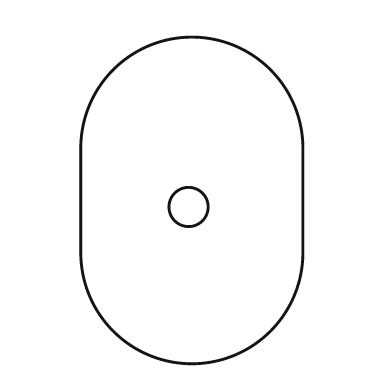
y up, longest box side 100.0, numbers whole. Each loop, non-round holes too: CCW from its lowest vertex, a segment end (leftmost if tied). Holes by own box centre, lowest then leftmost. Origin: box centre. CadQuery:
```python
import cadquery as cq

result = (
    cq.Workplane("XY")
    .moveTo(-34.0, -16.0)
    .threePointArc((0.0, -50.0), (34.0, -16.0))
    .lineTo(34.0, 16.0)
    .threePointArc((0.0, 50.0), (-34.0, 16.0))
    .close()
    .moveTo(-1.0, -2.0)
    .circle(6.0)
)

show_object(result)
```